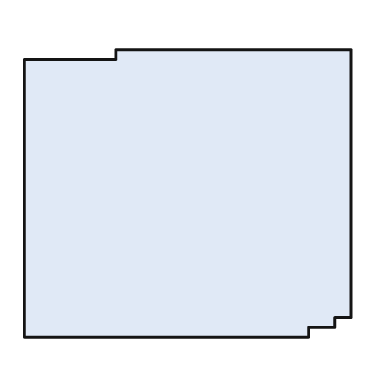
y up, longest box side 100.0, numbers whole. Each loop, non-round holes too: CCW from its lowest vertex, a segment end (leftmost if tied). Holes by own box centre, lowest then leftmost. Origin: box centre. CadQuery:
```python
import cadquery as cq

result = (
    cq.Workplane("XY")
    .moveTo(-50.0, -44.0)
    .lineTo(37.0, -44.0)
    .lineTo(37.0, -41.0)
    .lineTo(45.0, -41.0)
    .lineTo(45.0, -38.0)
    .lineTo(50.0, -38.0)
    .lineTo(50.0, 44.0)
    .lineTo(-22.0, 44.0)
    .lineTo(-22.0, 41.0)
    .lineTo(-50.0, 41.0)
    .close()
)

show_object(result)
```